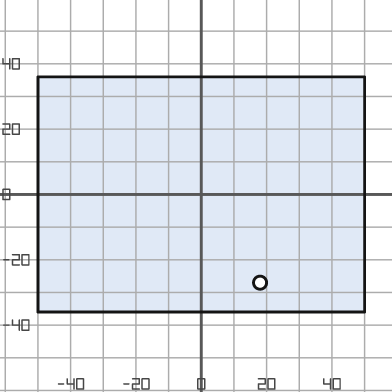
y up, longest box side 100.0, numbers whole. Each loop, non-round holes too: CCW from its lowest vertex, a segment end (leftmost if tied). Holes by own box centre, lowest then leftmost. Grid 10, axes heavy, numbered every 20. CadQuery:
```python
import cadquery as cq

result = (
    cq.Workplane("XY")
    .moveTo(-50.0, -36.0)
    .lineTo(50.0, -36.0)
    .lineTo(50.0, 36.0)
    .lineTo(-50.0, 36.0)
    .close()
    .moveTo(18.0, -27.0)
    .circle(2.0)
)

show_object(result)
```